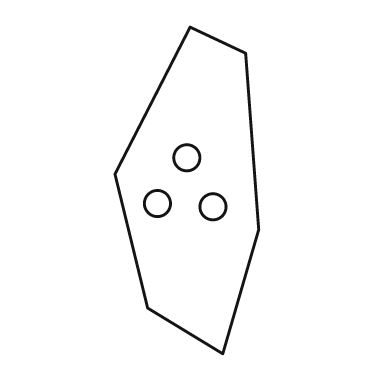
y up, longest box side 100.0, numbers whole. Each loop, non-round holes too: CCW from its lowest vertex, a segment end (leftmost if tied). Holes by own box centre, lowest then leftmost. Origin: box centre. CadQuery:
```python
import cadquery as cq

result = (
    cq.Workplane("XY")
    .moveTo(11.0, -50.0)
    .lineTo(22.0, -12.0)
    .lineTo(18.0, 42.0)
    .lineTo(1.0, 50.0)
    .lineTo(-22.0, 5.0)
    .lineTo(-12.0, -36.0)
    .close()
    .moveTo(8.0, -5.0)
    .circle(4.0)
    .moveTo(-9.0, -4.0)
    .circle(4.0)
    .moveTo(0.0, 10.0)
    .circle(4.0)
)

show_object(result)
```